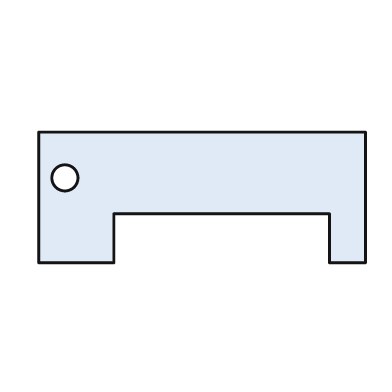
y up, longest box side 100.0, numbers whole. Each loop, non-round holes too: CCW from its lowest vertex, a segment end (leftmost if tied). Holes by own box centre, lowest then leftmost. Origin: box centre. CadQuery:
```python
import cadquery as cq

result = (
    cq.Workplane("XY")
    .moveTo(-50.0, -20.0)
    .lineTo(-27.0, -20.0)
    .lineTo(-27.0, -5.0)
    .lineTo(39.0, -5.0)
    .lineTo(39.0, -20.0)
    .lineTo(50.0, -20.0)
    .lineTo(50.0, 20.0)
    .lineTo(-50.0, 20.0)
    .close()
    .moveTo(-42.0, 6.0)
    .circle(4.0)
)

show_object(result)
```